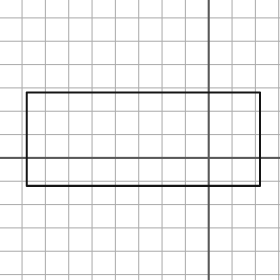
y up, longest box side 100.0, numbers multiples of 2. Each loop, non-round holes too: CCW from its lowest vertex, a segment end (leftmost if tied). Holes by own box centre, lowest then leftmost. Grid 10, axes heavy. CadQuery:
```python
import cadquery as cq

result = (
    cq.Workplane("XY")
    .moveTo(-78.0, -12.0)
    .lineTo(22.0, -12.0)
    .lineTo(22.0, 28.0)
    .lineTo(-78.0, 28.0)
    .close()
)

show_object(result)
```